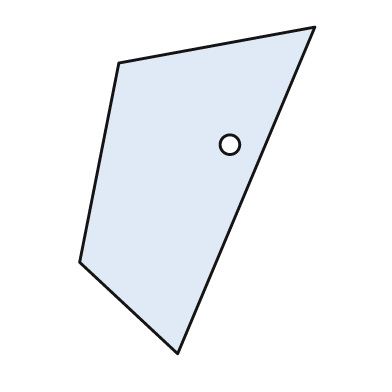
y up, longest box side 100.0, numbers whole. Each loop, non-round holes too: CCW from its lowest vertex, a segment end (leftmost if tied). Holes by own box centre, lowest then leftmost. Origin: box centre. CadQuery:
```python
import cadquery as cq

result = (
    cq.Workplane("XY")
    .moveTo(-6.0, -50.0)
    .lineTo(36.0, 50.0)
    .lineTo(-24.0, 39.0)
    .lineTo(-36.0, -22.0)
    .close()
    .moveTo(10.0, 14.0)
    .circle(3.0)
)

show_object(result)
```